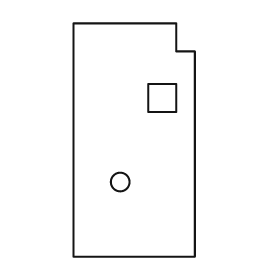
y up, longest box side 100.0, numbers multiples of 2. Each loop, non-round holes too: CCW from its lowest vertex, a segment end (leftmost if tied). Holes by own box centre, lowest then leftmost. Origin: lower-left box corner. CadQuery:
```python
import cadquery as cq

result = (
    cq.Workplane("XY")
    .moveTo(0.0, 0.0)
    .lineTo(52.0, 0.0)
    .lineTo(52.0, 88.0)
    .lineTo(44.0, 88.0)
    .lineTo(44.0, 100.0)
    .lineTo(0.0, 100.0)
    .close()
    .moveTo(20.0, 32.0)
    .circle(4.0)
    .moveTo(32.0, 62.0)
    .lineTo(44.0, 62.0)
    .lineTo(44.0, 74.0)
    .lineTo(32.0, 74.0)
    .close()
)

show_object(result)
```